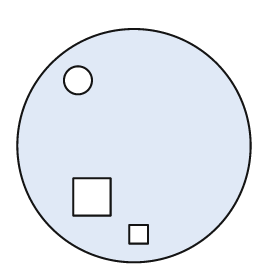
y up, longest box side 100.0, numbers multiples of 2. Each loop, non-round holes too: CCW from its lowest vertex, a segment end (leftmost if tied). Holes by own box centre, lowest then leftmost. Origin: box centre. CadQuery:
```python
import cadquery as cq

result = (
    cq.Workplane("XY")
    .moveTo(0.0, 0.0)
    .circle(50.0)
    .moveTo(-2.0, -42.0)
    .lineTo(6.0, -42.0)
    .lineTo(6.0, -34.0)
    .lineTo(-2.0, -34.0)
    .close()
    .moveTo(-26.0, -30.0)
    .lineTo(-10.0, -30.0)
    .lineTo(-10.0, -14.0)
    .lineTo(-26.0, -14.0)
    .close()
    .moveTo(-24.0, 28.0)
    .circle(6.0)
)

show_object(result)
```